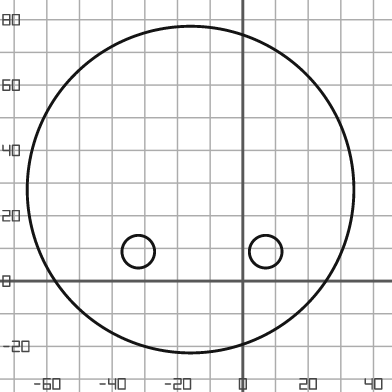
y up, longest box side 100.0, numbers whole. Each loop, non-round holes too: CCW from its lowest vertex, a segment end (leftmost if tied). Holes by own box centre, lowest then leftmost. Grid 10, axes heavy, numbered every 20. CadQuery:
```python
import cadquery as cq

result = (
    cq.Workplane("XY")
    .moveTo(-16.0, 28.0)
    .circle(50.0)
    .moveTo(-32.0, 9.0)
    .circle(5.0)
    .moveTo(7.0, 9.0)
    .circle(5.0)
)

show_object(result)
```